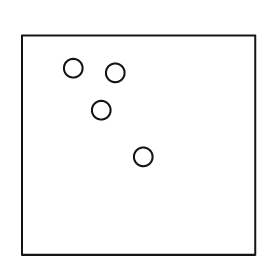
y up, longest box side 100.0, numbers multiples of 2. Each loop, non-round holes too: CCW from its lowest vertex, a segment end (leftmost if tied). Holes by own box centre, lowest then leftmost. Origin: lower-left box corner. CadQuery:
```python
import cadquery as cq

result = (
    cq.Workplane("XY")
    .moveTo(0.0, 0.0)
    .lineTo(100.0, 0.0)
    .lineTo(100.0, 94.0)
    .lineTo(0.0, 94.0)
    .close()
    .moveTo(52.0, 42.0)
    .circle(4.0)
    .moveTo(34.0, 62.0)
    .circle(4.0)
    .moveTo(40.0, 78.0)
    .circle(4.0)
    .moveTo(22.0, 80.0)
    .circle(4.0)
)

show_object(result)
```